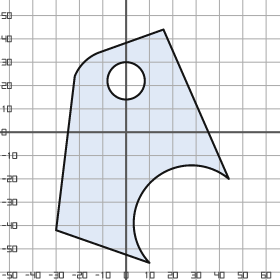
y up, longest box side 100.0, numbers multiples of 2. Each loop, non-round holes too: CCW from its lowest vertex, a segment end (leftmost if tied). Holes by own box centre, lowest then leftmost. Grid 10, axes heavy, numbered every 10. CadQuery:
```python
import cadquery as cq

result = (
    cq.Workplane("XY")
    .moveTo(10.0, -56.0)
    .threePointArc((10.0, -22.0), (44.0, -20.0))
    .lineTo(16.0, 44.0)
    .lineTo(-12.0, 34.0)
    .threePointArc((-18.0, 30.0), (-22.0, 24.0))
    .lineTo(-30.0, -42.0)
    .close()
    .moveTo(0.0, 22.0)
    .circle(8.0)
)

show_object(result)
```